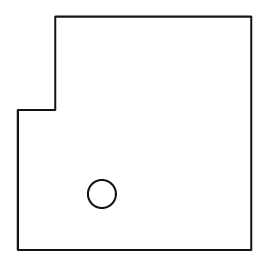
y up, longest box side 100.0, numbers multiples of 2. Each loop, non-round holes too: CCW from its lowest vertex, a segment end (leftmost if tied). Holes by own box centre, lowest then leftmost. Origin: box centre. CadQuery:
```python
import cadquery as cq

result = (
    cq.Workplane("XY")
    .moveTo(-50.0, -50.0)
    .lineTo(50.0, -50.0)
    .lineTo(50.0, 50.0)
    .lineTo(-34.0, 50.0)
    .lineTo(-34.0, 10.0)
    .lineTo(-50.0, 10.0)
    .close()
    .moveTo(-14.0, -26.0)
    .circle(6.0)
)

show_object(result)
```